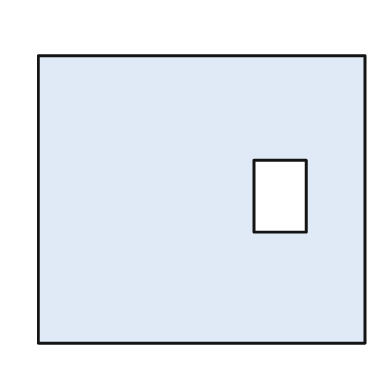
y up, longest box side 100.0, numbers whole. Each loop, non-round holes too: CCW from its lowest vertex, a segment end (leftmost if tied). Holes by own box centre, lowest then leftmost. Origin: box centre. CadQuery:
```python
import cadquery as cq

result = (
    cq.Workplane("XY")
    .moveTo(-50.0, -44.0)
    .lineTo(50.0, -44.0)
    .lineTo(50.0, 44.0)
    .lineTo(-50.0, 44.0)
    .close()
    .moveTo(16.0, -10.0)
    .lineTo(32.0, -10.0)
    .lineTo(32.0, 12.0)
    .lineTo(16.0, 12.0)
    .close()
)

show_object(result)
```